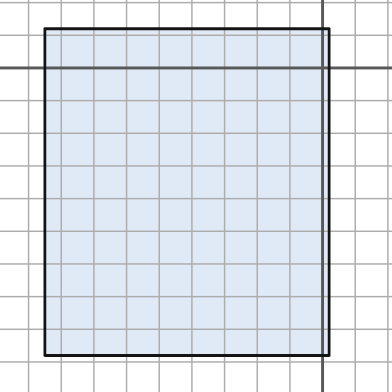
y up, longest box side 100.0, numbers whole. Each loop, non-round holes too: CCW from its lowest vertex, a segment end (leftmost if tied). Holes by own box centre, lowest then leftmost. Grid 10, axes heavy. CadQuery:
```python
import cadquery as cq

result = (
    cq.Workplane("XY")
    .moveTo(-85.0, -88.0)
    .lineTo(2.0, -88.0)
    .lineTo(2.0, 12.0)
    .lineTo(-85.0, 12.0)
    .close()
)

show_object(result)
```